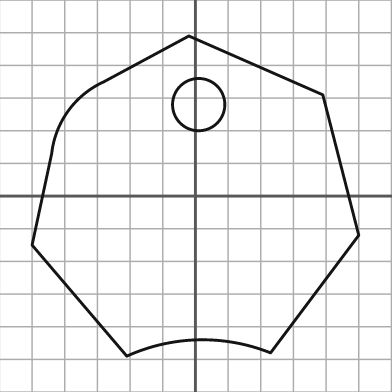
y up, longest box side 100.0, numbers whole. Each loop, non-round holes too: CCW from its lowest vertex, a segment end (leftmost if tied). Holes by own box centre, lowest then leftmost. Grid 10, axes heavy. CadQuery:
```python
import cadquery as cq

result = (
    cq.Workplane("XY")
    .moveTo(-21.0, -49.0)
    .threePointArc((1.0, -44.0), (23.0, -48.0))
    .lineTo(50.0, -12.0)
    .lineTo(39.0, 31.0)
    .lineTo(-2.0, 49.0)
    .lineTo(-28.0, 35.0)
    .threePointArc((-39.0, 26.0), (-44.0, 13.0))
    .lineTo(-50.0, -15.0)
    .close()
    .moveTo(1.0, 28.0)
    .circle(8.0)
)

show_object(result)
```